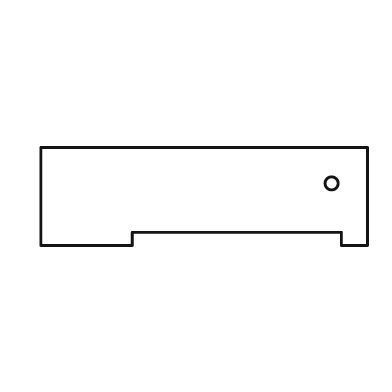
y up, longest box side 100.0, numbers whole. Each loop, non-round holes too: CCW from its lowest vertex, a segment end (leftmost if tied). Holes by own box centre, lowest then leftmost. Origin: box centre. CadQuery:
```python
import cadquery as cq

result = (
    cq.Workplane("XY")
    .moveTo(-50.0, -15.0)
    .lineTo(-22.0, -15.0)
    .lineTo(-22.0, -11.0)
    .lineTo(42.0, -11.0)
    .lineTo(42.0, -15.0)
    .lineTo(50.0, -15.0)
    .lineTo(50.0, 15.0)
    .lineTo(-50.0, 15.0)
    .close()
    .moveTo(39.0, 4.0)
    .circle(2.0)
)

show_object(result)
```